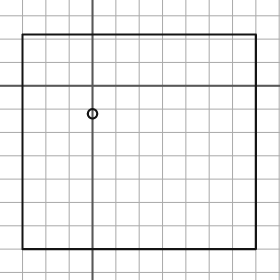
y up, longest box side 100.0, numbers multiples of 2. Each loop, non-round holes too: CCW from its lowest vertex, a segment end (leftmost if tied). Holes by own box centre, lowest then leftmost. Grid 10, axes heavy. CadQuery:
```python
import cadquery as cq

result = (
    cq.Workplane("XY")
    .moveTo(-30.0, -70.0)
    .lineTo(70.0, -70.0)
    .lineTo(70.0, 22.0)
    .lineTo(-30.0, 22.0)
    .close()
    .moveTo(0.0, -12.0)
    .circle(2.0)
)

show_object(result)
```